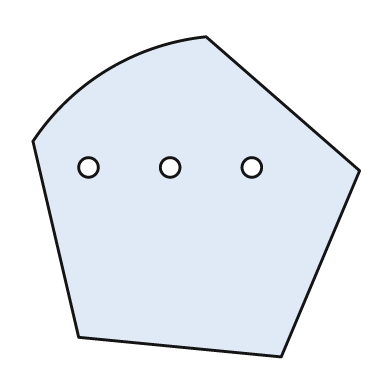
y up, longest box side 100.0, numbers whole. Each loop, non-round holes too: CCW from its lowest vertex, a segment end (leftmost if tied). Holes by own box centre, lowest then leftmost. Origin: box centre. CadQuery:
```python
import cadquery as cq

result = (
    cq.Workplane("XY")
    .moveTo(26.0, -49.0)
    .lineTo(50.0, 8.0)
    .lineTo(3.0, 49.0)
    .threePointArc((-27.0, 39.0), (-50.0, 17.0))
    .lineTo(-36.0, -43.0)
    .close()
    .moveTo(-33.0, 9.0)
    .circle(3.0)
    .moveTo(-8.0, 9.0)
    .circle(3.0)
    .moveTo(17.0, 9.0)
    .circle(3.0)
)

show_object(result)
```